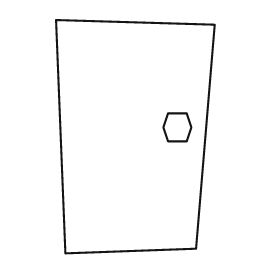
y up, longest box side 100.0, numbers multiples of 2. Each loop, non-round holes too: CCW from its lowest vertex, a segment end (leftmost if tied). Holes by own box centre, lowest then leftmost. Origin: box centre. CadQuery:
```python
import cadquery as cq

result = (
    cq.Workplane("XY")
    .moveTo(-30.0, -50.0)
    .lineTo(26.0, -48.0)
    .lineTo(34.0, 48.0)
    .lineTo(-34.0, 50.0)
    .close()
    .moveTo(14.0, -2.0)
    .lineTo(22.0, -2.0)
    .lineTo(24.0, 4.0)
    .lineTo(22.0, 10.0)
    .lineTo(14.0, 10.0)
    .lineTo(12.0, 4.0)
    .close()
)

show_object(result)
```